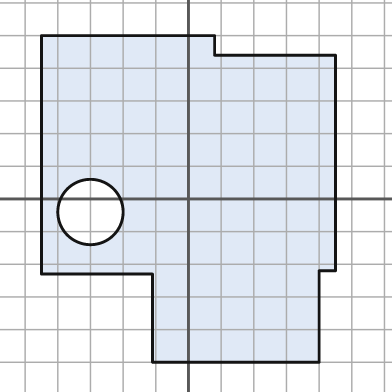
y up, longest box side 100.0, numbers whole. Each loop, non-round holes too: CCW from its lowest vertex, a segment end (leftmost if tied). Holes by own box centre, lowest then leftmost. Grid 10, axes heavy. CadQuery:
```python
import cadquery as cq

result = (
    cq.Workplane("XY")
    .moveTo(-11.0, -50.0)
    .lineTo(40.0, -50.0)
    .lineTo(40.0, -22.0)
    .lineTo(45.0, -22.0)
    .lineTo(45.0, 44.0)
    .lineTo(8.0, 44.0)
    .lineTo(8.0, 50.0)
    .lineTo(-45.0, 50.0)
    .lineTo(-45.0, -23.0)
    .lineTo(-11.0, -23.0)
    .close()
    .moveTo(-30.0, -4.0)
    .circle(10.0)
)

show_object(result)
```